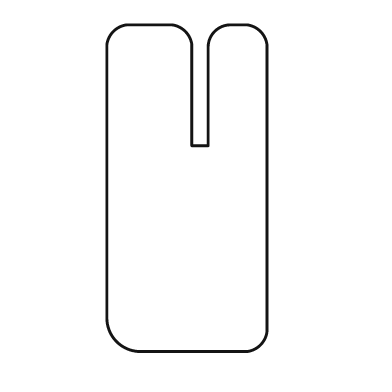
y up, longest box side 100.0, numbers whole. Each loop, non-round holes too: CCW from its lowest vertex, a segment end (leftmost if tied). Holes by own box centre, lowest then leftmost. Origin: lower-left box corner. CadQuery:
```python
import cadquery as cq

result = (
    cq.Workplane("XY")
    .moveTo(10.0, 0.0)
    .lineTo(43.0, 0.0)
    .threePointArc((47.0, 2.0), (49.0, 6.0))
    .lineTo(49.0, 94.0)
    .threePointArc((47.0, 98.0), (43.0, 100.0))
    .lineTo(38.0, 100.0)
    .threePointArc((33.0, 98.0), (31.0, 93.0))
    .lineTo(31.0, 63.0)
    .lineTo(26.0, 63.0)
    .lineTo(26.0, 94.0)
    .threePointArc((24.0, 98.0), (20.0, 100.0))
    .lineTo(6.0, 100.0)
    .threePointArc((2.0, 98.0), (0.0, 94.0))
    .lineTo(0.0, 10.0)
    .threePointArc((3.0, 3.0), (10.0, 0.0))
    .close()
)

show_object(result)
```